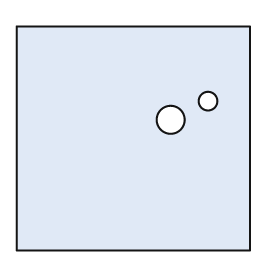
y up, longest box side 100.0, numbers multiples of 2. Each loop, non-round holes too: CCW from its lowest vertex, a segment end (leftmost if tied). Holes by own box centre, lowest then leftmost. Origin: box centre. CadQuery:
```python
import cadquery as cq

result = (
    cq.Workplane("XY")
    .moveTo(-50.0, -48.0)
    .lineTo(50.0, -48.0)
    .lineTo(50.0, 48.0)
    .lineTo(-50.0, 48.0)
    .close()
    .moveTo(16.0, 8.0)
    .circle(6.0)
    .moveTo(32.0, 16.0)
    .circle(4.0)
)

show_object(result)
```